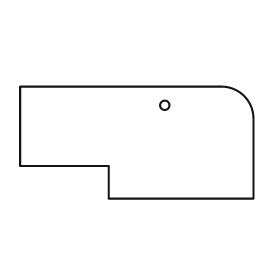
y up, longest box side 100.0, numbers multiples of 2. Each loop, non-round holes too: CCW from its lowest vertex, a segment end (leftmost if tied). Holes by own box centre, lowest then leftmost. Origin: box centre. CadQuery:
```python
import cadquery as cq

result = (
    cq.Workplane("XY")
    .moveTo(-12.0, -24.0)
    .lineTo(50.0, -24.0)
    .lineTo(50.0, 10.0)
    .threePointArc((46.0, 20.0), (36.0, 24.0))
    .lineTo(-50.0, 24.0)
    .lineTo(-50.0, -10.0)
    .lineTo(-12.0, -10.0)
    .close()
    .moveTo(12.0, 16.0)
    .circle(2.0)
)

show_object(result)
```